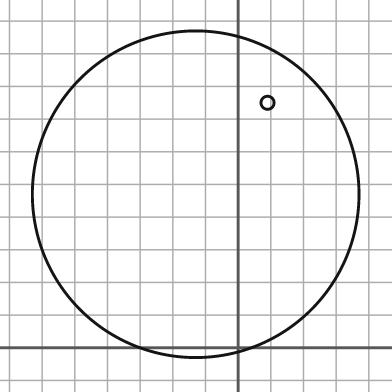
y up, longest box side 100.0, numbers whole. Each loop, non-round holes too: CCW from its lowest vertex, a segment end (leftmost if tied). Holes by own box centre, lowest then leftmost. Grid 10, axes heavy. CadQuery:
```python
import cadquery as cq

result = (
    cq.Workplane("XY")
    .moveTo(-13.0, 47.0)
    .circle(50.0)
    .moveTo(9.0, 75.0)
    .circle(2.0)
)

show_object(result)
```